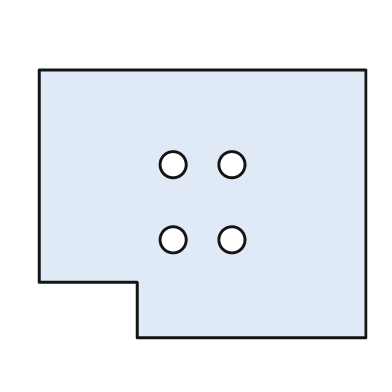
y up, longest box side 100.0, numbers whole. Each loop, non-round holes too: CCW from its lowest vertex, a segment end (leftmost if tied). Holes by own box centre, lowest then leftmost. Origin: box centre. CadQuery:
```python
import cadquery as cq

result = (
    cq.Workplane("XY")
    .moveTo(-20.0, -41.0)
    .lineTo(50.0, -41.0)
    .lineTo(50.0, 41.0)
    .lineTo(-50.0, 41.0)
    .lineTo(-50.0, -24.0)
    .lineTo(-20.0, -24.0)
    .close()
    .moveTo(-9.0, -11.0)
    .circle(4.0)
    .moveTo(9.0, -11.0)
    .circle(4.0)
    .moveTo(-9.0, 12.0)
    .circle(4.0)
    .moveTo(9.0, 12.0)
    .circle(4.0)
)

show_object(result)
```